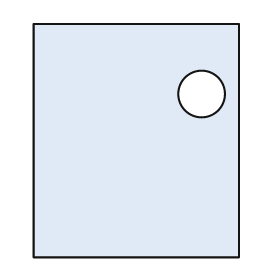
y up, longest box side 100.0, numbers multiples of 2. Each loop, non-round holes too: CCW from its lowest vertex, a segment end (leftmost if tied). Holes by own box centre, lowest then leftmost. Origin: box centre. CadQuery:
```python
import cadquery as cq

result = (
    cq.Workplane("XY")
    .moveTo(-44.0, -50.0)
    .lineTo(44.0, -50.0)
    .lineTo(44.0, 50.0)
    .lineTo(-44.0, 50.0)
    .close()
    .moveTo(28.0, 20.0)
    .circle(10.0)
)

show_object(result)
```